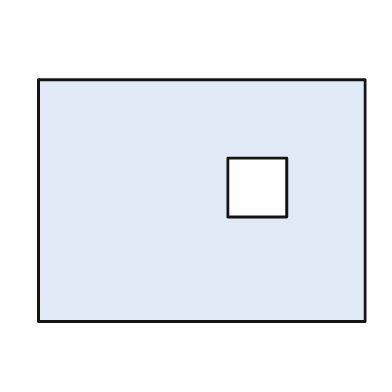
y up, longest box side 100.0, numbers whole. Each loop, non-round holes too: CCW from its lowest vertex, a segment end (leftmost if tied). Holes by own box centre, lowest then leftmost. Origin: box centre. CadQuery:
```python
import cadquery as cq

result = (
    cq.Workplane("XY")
    .moveTo(-50.0, -37.0)
    .lineTo(50.0, -37.0)
    .lineTo(50.0, 37.0)
    .lineTo(-50.0, 37.0)
    .close()
    .moveTo(8.0, -5.0)
    .lineTo(26.0, -5.0)
    .lineTo(26.0, 13.0)
    .lineTo(8.0, 13.0)
    .close()
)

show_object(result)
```